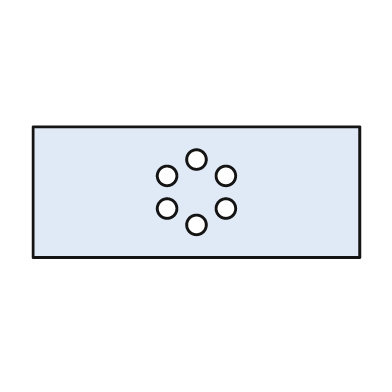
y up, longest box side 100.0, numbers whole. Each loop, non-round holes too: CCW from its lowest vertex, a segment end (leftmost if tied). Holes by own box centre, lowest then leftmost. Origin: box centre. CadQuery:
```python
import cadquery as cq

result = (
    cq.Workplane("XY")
    .moveTo(-50.0, -20.0)
    .lineTo(50.0, -20.0)
    .lineTo(50.0, 20.0)
    .lineTo(-50.0, 20.0)
    .close()
    .moveTo(0.0, -10.0)
    .circle(3.0)
    .moveTo(-9.0, -5.0)
    .circle(3.0)
    .moveTo(9.0, -5.0)
    .circle(3.0)
    .moveTo(-9.0, 5.0)
    .circle(3.0)
    .moveTo(9.0, 5.0)
    .circle(3.0)
    .moveTo(0.0, 10.0)
    .circle(3.0)
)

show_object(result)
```